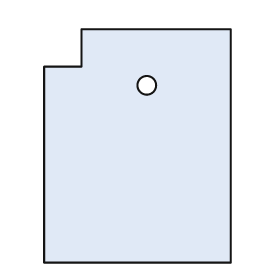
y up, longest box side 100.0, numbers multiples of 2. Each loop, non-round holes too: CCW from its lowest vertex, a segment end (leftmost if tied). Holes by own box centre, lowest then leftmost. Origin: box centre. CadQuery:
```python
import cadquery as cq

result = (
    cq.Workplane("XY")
    .moveTo(-40.0, -50.0)
    .lineTo(40.0, -50.0)
    .lineTo(40.0, 50.0)
    .lineTo(-24.0, 50.0)
    .lineTo(-24.0, 34.0)
    .lineTo(-40.0, 34.0)
    .close()
    .moveTo(4.0, 26.0)
    .circle(4.0)
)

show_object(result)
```